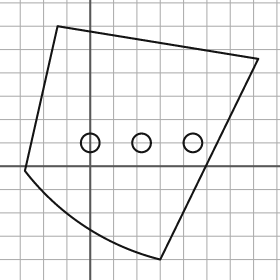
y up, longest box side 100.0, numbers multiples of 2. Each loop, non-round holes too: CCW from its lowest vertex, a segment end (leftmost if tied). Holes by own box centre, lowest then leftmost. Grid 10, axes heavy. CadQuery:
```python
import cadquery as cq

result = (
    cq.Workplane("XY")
    .moveTo(30.0, -40.0)
    .lineTo(72.0, 46.0)
    .lineTo(-14.0, 60.0)
    .lineTo(-28.0, -2.0)
    .threePointArc((-2.0, -26.0), (30.0, -40.0))
    .close()
    .moveTo(0.0, 10.0)
    .circle(4.0)
    .moveTo(22.0, 10.0)
    .circle(4.0)
    .moveTo(44.0, 10.0)
    .circle(4.0)
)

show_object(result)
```